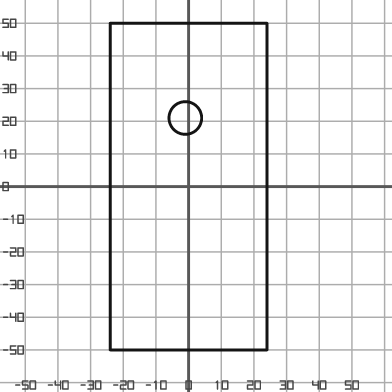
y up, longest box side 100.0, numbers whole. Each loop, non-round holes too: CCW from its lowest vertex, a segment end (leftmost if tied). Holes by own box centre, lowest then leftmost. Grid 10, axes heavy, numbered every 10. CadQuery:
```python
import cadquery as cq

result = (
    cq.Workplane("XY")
    .moveTo(-24.0, -50.0)
    .lineTo(24.0, -50.0)
    .lineTo(24.0, 50.0)
    .lineTo(-24.0, 50.0)
    .close()
    .moveTo(-1.0, 21.0)
    .circle(5.0)
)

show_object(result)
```